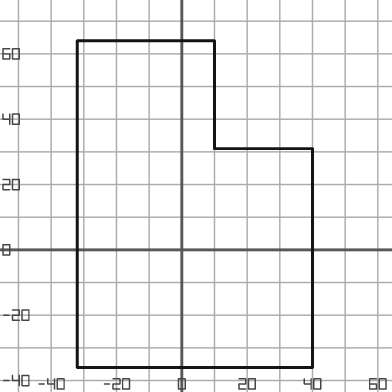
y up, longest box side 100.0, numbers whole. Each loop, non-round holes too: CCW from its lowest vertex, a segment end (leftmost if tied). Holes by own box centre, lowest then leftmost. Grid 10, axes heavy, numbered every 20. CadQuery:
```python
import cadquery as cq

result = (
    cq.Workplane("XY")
    .moveTo(-32.0, -36.0)
    .lineTo(40.0, -36.0)
    .lineTo(40.0, 31.0)
    .lineTo(10.0, 31.0)
    .lineTo(10.0, 64.0)
    .lineTo(-32.0, 64.0)
    .close()
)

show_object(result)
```